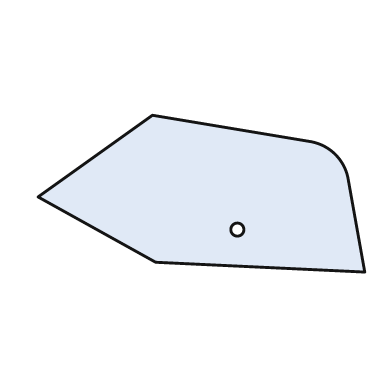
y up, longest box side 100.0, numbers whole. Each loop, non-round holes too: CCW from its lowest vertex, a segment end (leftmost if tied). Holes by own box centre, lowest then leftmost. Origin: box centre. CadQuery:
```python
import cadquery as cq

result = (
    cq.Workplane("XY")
    .moveTo(50.0, -24.0)
    .lineTo(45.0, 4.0)
    .threePointArc((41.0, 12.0), (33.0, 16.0))
    .lineTo(-15.0, 24.0)
    .lineTo(-50.0, -1.0)
    .lineTo(-14.0, -21.0)
    .close()
    .moveTo(11.0, -11.0)
    .circle(2.0)
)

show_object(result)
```